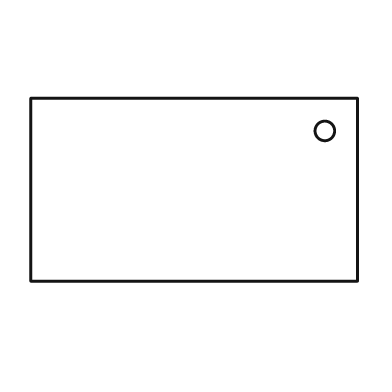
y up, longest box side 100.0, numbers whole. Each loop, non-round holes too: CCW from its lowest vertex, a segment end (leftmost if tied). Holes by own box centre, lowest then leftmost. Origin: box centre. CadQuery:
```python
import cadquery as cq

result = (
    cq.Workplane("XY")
    .moveTo(-50.0, -28.0)
    .lineTo(50.0, -28.0)
    .lineTo(50.0, 28.0)
    .lineTo(-50.0, 28.0)
    .close()
    .moveTo(40.0, 18.0)
    .circle(3.0)
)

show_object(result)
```